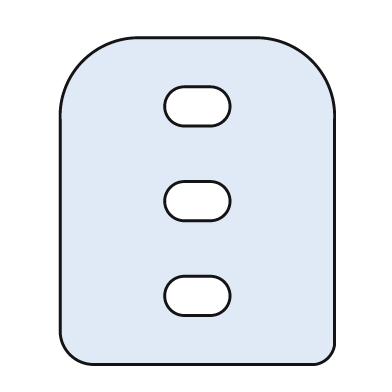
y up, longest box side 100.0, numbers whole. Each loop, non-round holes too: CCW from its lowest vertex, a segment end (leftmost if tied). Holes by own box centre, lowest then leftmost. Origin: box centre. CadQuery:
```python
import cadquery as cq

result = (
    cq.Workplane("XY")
    .moveTo(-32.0, -50.0)
    .lineTo(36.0, -50.0)
    .threePointArc((40.0, -48.0), (42.0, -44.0))
    .lineTo(42.0, 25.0)
    .threePointArc((35.0, 43.0), (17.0, 50.0))
    .lineTo(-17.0, 50.0)
    .threePointArc((-35.0, 43.0), (-42.0, 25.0))
    .lineTo(-42.0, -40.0)
    .threePointArc((-39.0, -47.0), (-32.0, -50.0))
    .close()
    .moveTo(-4.0, -35.0)
    .lineTo(4.0, -35.0)
    .threePointArc((10.0, -29.0), (4.0, -23.0))
    .lineTo(-4.0, -23.0)
    .threePointArc((-10.0, -29.0), (-4.0, -35.0))
    .close()
    .moveTo(-4.0, -6.0)
    .lineTo(4.0, -6.0)
    .threePointArc((10.0, 0.0), (4.0, 6.0))
    .lineTo(-4.0, 6.0)
    .threePointArc((-10.0, 0.0), (-4.0, -6.0))
    .close()
    .moveTo(-4.0, 23.0)
    .lineTo(4.0, 23.0)
    .threePointArc((10.0, 29.0), (4.0, 35.0))
    .lineTo(-4.0, 35.0)
    .threePointArc((-10.0, 29.0), (-4.0, 23.0))
    .close()
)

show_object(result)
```